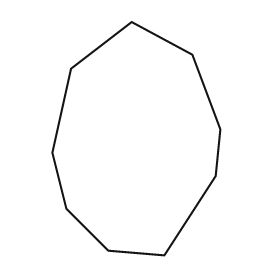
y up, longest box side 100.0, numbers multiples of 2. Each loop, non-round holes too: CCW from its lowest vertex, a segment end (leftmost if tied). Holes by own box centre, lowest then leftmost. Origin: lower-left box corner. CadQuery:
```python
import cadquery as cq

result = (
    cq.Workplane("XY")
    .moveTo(48.0, 0.0)
    .lineTo(70.0, 34.0)
    .lineTo(72.0, 54.0)
    .lineTo(60.0, 86.0)
    .lineTo(34.0, 100.0)
    .lineTo(8.0, 80.0)
    .lineTo(0.0, 44.0)
    .lineTo(6.0, 20.0)
    .lineTo(24.0, 2.0)
    .close()
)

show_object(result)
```